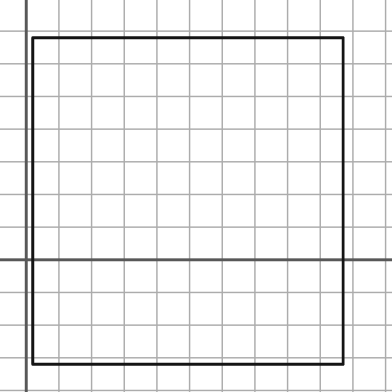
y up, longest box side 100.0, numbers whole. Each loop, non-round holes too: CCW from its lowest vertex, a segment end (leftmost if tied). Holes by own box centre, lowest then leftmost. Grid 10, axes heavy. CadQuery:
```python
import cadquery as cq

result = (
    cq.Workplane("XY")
    .moveTo(2.0, -32.0)
    .lineTo(97.0, -32.0)
    .lineTo(97.0, 68.0)
    .lineTo(2.0, 68.0)
    .close()
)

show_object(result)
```